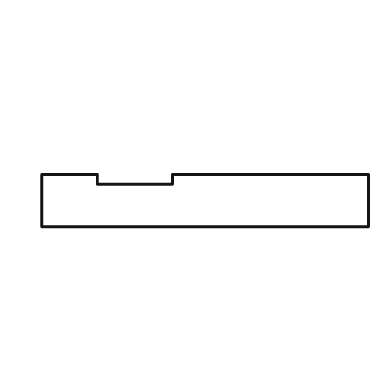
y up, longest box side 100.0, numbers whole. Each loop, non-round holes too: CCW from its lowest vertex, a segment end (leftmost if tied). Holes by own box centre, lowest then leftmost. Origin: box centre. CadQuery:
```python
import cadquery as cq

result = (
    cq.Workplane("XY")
    .moveTo(-50.0, -8.0)
    .lineTo(50.0, -8.0)
    .lineTo(50.0, 8.0)
    .lineTo(-10.0, 8.0)
    .lineTo(-10.0, 5.0)
    .lineTo(-33.0, 5.0)
    .lineTo(-33.0, 8.0)
    .lineTo(-50.0, 8.0)
    .close()
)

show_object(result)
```